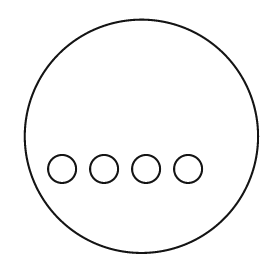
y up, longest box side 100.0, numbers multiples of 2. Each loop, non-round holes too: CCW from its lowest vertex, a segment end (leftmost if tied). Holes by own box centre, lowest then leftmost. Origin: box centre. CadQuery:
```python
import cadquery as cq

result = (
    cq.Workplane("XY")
    .moveTo(0.0, 0.0)
    .circle(50.0)
    .moveTo(-34.0, -14.0)
    .circle(6.0)
    .moveTo(-16.0, -14.0)
    .circle(6.0)
    .moveTo(2.0, -14.0)
    .circle(6.0)
    .moveTo(20.0, -14.0)
    .circle(6.0)
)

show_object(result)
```